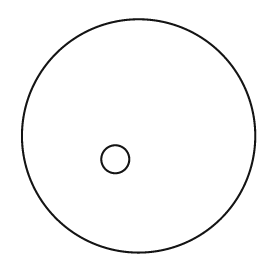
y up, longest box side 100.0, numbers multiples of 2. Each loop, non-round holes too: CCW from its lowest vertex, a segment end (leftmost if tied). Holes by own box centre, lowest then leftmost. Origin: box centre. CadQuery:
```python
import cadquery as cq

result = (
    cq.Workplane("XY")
    .moveTo(0.0, 0.0)
    .circle(50.0)
    .moveTo(-10.0, -10.0)
    .circle(6.0)
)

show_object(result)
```